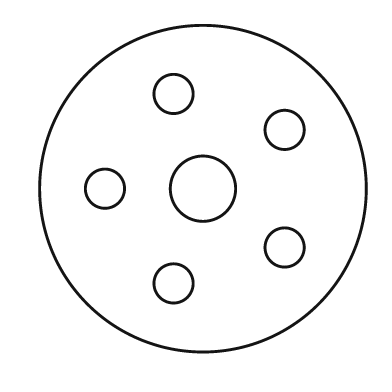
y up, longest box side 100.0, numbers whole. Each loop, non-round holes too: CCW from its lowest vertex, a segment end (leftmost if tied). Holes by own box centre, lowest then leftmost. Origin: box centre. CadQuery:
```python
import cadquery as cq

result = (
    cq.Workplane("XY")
    .moveTo(0.0, 0.0)
    .circle(50.0)
    .moveTo(-9.0, -29.0)
    .circle(6.0)
    .moveTo(25.0, -18.0)
    .circle(6.0)
    .moveTo(-30.0, 0.0)
    .circle(6.0)
    .moveTo(0.0, 0.0)
    .circle(10.0)
    .moveTo(25.0, 18.0)
    .circle(6.0)
    .moveTo(-9.0, 29.0)
    .circle(6.0)
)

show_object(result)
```